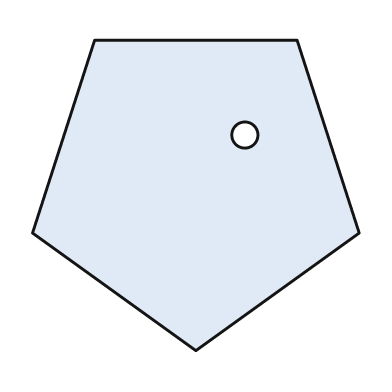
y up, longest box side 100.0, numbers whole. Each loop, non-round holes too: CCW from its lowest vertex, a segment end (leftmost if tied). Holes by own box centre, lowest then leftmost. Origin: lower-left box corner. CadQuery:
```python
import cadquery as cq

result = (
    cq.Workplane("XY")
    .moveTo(50.0, 0.0)
    .lineTo(100.0, 36.0)
    .lineTo(81.0, 95.0)
    .lineTo(19.0, 95.0)
    .lineTo(0.0, 36.0)
    .close()
    .moveTo(65.0, 66.0)
    .circle(4.0)
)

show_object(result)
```